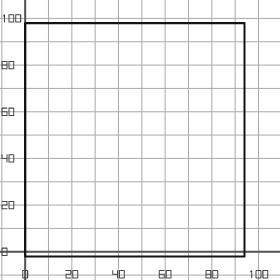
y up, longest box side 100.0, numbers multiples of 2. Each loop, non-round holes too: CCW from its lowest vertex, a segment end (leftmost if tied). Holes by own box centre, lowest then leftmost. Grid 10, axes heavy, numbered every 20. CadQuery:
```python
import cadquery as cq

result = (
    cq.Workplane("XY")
    .moveTo(0.0, -2.0)
    .lineTo(94.0, -2.0)
    .lineTo(94.0, 98.0)
    .lineTo(0.0, 98.0)
    .close()
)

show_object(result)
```